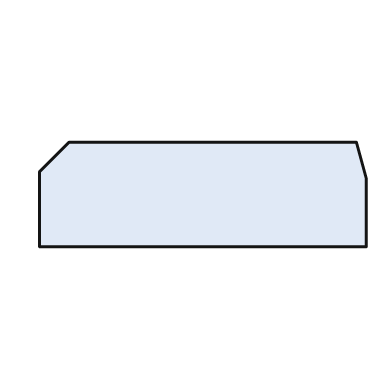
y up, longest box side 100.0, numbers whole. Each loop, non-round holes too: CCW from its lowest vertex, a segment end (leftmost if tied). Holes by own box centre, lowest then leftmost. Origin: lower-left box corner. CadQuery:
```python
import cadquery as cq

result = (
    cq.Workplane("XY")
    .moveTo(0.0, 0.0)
    .lineTo(100.0, 0.0)
    .lineTo(100.0, 21.0)
    .lineTo(97.0, 32.0)
    .lineTo(9.0, 32.0)
    .lineTo(0.0, 23.0)
    .close()
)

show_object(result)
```